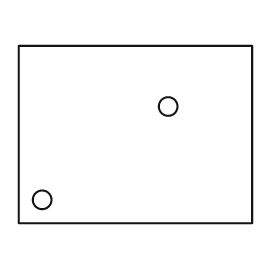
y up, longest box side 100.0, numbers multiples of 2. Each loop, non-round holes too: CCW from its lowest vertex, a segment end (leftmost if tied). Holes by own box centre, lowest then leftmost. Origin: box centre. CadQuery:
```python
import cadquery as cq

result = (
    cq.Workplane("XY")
    .moveTo(-50.0, -38.0)
    .lineTo(50.0, -38.0)
    .lineTo(50.0, 38.0)
    .lineTo(-50.0, 38.0)
    .close()
    .moveTo(-40.0, -28.0)
    .circle(4.0)
    .moveTo(14.0, 12.0)
    .circle(4.0)
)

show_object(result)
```